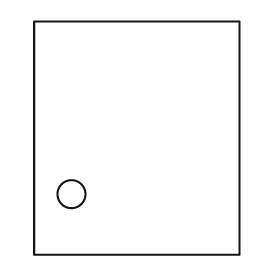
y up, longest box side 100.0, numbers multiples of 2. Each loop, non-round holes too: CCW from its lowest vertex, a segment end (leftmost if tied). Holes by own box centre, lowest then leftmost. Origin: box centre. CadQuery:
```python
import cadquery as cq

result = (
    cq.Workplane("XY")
    .moveTo(-44.0, -50.0)
    .lineTo(44.0, -50.0)
    .lineTo(44.0, 50.0)
    .lineTo(-44.0, 50.0)
    .close()
    .moveTo(-28.0, -24.0)
    .circle(6.0)
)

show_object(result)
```